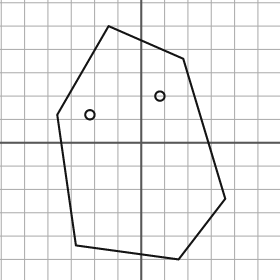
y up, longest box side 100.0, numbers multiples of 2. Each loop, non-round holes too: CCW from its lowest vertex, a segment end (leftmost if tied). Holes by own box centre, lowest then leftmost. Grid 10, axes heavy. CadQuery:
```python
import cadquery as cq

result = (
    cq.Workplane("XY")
    .moveTo(16.0, -50.0)
    .lineTo(36.0, -24.0)
    .lineTo(18.0, 36.0)
    .lineTo(-14.0, 50.0)
    .lineTo(-36.0, 12.0)
    .lineTo(-28.0, -44.0)
    .close()
    .moveTo(-22.0, 12.0)
    .circle(2.0)
    .moveTo(8.0, 20.0)
    .circle(2.0)
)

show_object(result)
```